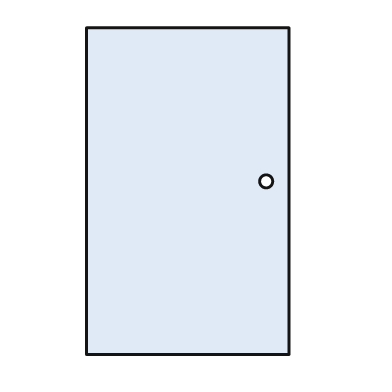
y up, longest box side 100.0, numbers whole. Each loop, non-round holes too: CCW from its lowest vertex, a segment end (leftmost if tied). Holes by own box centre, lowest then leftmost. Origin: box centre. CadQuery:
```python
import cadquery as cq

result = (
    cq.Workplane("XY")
    .moveTo(-31.0, -50.0)
    .lineTo(31.0, -50.0)
    .lineTo(31.0, 50.0)
    .lineTo(-31.0, 50.0)
    .close()
    .moveTo(24.0, 3.0)
    .circle(2.0)
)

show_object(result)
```